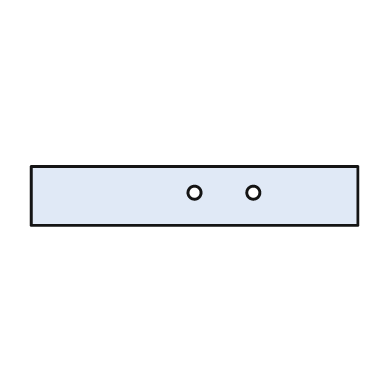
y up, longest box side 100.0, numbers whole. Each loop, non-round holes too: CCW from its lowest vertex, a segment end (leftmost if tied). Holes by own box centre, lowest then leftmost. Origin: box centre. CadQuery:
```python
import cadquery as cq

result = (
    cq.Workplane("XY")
    .moveTo(-50.0, -9.0)
    .lineTo(50.0, -9.0)
    .lineTo(50.0, 9.0)
    .lineTo(-50.0, 9.0)
    .close()
    .moveTo(0.0, 1.0)
    .circle(2.0)
    .moveTo(18.0, 1.0)
    .circle(2.0)
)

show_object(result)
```